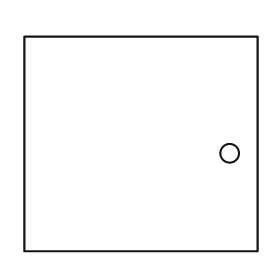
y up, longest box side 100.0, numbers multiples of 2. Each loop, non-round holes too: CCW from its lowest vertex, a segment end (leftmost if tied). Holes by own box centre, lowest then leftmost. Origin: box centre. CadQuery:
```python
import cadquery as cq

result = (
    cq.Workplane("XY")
    .moveTo(-50.0, -46.0)
    .lineTo(50.0, -46.0)
    .lineTo(50.0, 46.0)
    .lineTo(-50.0, 46.0)
    .close()
    .moveTo(38.0, -4.0)
    .circle(4.0)
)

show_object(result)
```